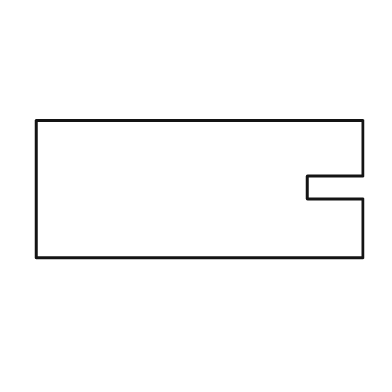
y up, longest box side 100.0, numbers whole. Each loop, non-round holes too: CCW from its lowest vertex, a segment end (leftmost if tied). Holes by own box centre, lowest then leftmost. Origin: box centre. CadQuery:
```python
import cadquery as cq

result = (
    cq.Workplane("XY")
    .moveTo(-50.0, -21.0)
    .lineTo(50.0, -21.0)
    .lineTo(50.0, -3.0)
    .lineTo(33.0, -3.0)
    .lineTo(33.0, 4.0)
    .lineTo(50.0, 4.0)
    .lineTo(50.0, 21.0)
    .lineTo(-50.0, 21.0)
    .close()
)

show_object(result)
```